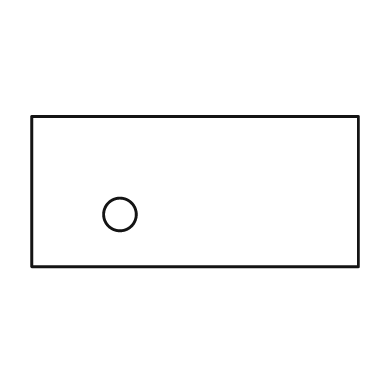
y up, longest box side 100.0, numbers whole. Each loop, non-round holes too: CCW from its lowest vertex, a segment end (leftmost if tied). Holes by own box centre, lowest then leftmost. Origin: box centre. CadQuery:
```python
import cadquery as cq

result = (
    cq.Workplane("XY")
    .moveTo(-50.0, -23.0)
    .lineTo(50.0, -23.0)
    .lineTo(50.0, 23.0)
    .lineTo(-50.0, 23.0)
    .close()
    .moveTo(-23.0, -7.0)
    .circle(5.0)
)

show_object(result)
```